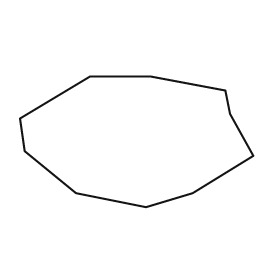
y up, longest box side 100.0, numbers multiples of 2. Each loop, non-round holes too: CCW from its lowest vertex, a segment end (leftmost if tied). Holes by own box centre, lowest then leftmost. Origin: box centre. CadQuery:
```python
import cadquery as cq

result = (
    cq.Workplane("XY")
    .moveTo(4.0, -28.0)
    .lineTo(24.0, -22.0)
    .lineTo(50.0, -6.0)
    .lineTo(40.0, 12.0)
    .lineTo(38.0, 22.0)
    .lineTo(6.0, 28.0)
    .lineTo(-20.0, 28.0)
    .lineTo(-50.0, 10.0)
    .lineTo(-48.0, -4.0)
    .lineTo(-26.0, -22.0)
    .close()
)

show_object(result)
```